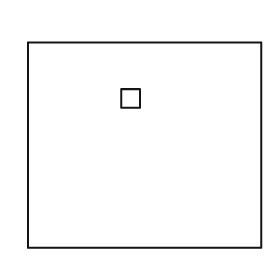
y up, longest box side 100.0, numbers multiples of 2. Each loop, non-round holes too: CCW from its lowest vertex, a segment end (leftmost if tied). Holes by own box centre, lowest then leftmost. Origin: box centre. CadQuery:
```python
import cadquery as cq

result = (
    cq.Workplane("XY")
    .moveTo(-50.0, -44.0)
    .lineTo(50.0, -44.0)
    .lineTo(50.0, 44.0)
    .lineTo(-50.0, 44.0)
    .close()
    .moveTo(-10.0, 16.0)
    .lineTo(-2.0, 16.0)
    .lineTo(-2.0, 24.0)
    .lineTo(-10.0, 24.0)
    .close()
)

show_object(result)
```